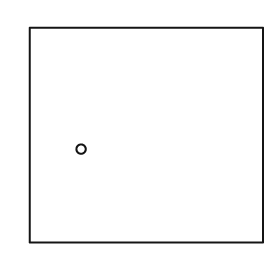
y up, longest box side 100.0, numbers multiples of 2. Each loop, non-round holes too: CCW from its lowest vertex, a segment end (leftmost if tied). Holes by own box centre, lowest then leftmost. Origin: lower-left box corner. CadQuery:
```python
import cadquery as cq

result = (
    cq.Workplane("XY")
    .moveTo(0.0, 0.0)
    .lineTo(100.0, 0.0)
    .lineTo(100.0, 92.0)
    .lineTo(0.0, 92.0)
    .close()
    .moveTo(22.0, 40.0)
    .circle(2.0)
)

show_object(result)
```